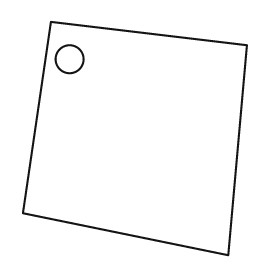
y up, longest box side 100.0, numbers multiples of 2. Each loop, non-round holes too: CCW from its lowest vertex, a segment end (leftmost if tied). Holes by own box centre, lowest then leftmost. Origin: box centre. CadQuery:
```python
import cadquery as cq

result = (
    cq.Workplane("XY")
    .moveTo(40.0, -50.0)
    .lineTo(48.0, 40.0)
    .lineTo(-36.0, 50.0)
    .lineTo(-48.0, -32.0)
    .close()
    .moveTo(-28.0, 34.0)
    .circle(6.0)
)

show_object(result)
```